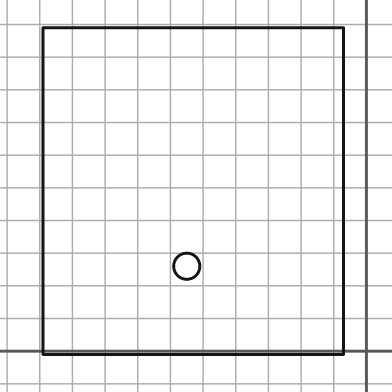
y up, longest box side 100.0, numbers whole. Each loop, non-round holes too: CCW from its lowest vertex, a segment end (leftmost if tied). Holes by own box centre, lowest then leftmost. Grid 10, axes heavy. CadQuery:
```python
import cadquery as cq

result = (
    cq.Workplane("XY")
    .moveTo(-99.0, -1.0)
    .lineTo(-7.0, -1.0)
    .lineTo(-7.0, 99.0)
    .lineTo(-99.0, 99.0)
    .close()
    .moveTo(-55.0, 26.0)
    .circle(4.0)
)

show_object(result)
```